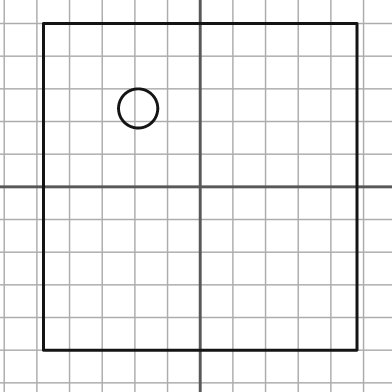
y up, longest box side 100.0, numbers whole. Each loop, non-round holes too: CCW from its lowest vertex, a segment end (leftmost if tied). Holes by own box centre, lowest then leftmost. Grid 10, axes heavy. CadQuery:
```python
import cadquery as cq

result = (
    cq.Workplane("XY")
    .moveTo(-48.0, -50.0)
    .lineTo(48.0, -50.0)
    .lineTo(48.0, 50.0)
    .lineTo(-48.0, 50.0)
    .close()
    .moveTo(-19.0, 24.0)
    .circle(6.0)
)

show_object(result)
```